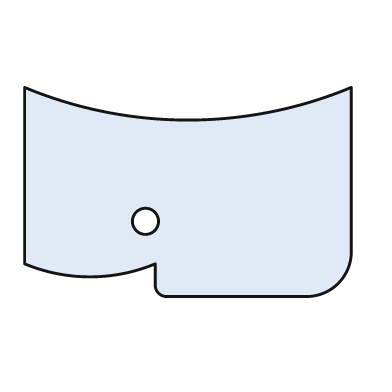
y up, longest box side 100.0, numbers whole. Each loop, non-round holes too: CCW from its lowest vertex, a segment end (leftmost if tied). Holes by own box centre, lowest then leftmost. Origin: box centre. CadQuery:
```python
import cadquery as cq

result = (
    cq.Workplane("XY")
    .moveTo(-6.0, -32.0)
    .lineTo(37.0, -32.0)
    .threePointArc((46.0, -28.0), (50.0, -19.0))
    .lineTo(50.0, 32.0)
    .threePointArc((0.0, 22.0), (-50.0, 32.0))
    .lineTo(-50.0, -22.0)
    .threePointArc((-30.0, -26.0), (-10.0, -22.0))
    .lineTo(-10.0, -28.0)
    .threePointArc((-9.0, -31.0), (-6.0, -32.0))
    .close()
    .moveTo(-13.0, -9.0)
    .circle(4.0)
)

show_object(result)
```